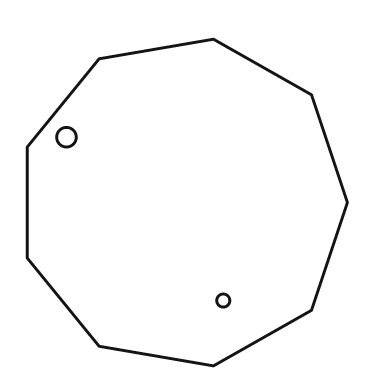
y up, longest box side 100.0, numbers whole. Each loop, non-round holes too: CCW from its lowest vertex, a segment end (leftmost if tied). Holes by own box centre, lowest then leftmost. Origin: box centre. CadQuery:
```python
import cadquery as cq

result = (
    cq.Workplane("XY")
    .moveTo(8.0, -50.0)
    .lineTo(38.0, -33.0)
    .lineTo(49.0, 0.0)
    .lineTo(38.0, 33.0)
    .lineTo(8.0, 50.0)
    .lineTo(-27.0, 44.0)
    .lineTo(-49.0, 17.0)
    .lineTo(-49.0, -17.0)
    .lineTo(-27.0, -44.0)
    .close()
    .moveTo(11.0, -30.0)
    .circle(2.0)
    .moveTo(-37.0, 20.0)
    .circle(3.0)
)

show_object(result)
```